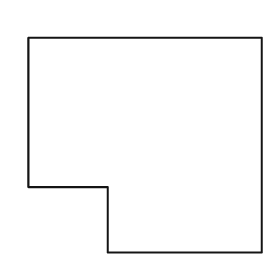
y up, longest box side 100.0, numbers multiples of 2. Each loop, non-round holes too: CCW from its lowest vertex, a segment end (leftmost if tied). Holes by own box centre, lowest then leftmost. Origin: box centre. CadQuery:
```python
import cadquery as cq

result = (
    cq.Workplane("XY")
    .moveTo(-16.0, -46.0)
    .lineTo(50.0, -46.0)
    .lineTo(50.0, 46.0)
    .lineTo(-50.0, 46.0)
    .lineTo(-50.0, -18.0)
    .lineTo(-16.0, -18.0)
    .close()
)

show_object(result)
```